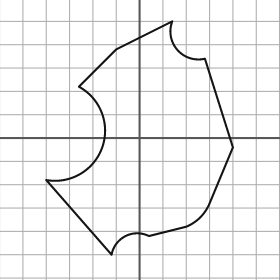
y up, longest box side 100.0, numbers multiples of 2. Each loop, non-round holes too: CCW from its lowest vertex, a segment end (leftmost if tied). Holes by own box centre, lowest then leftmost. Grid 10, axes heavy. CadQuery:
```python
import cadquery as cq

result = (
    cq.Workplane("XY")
    .moveTo(-12.0, -50.0)
    .threePointArc((-6.0, -42.0), (4.0, -42.0))
    .lineTo(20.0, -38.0)
    .threePointArc((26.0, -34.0), (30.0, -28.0))
    .lineTo(40.0, -4.0)
    .lineTo(28.0, 34.0)
    .threePointArc((16.0, 38.0), (14.0, 50.0))
    .lineTo(-10.0, 38.0)
    .lineTo(-26.0, 22.0)
    .threePointArc((-16.0, -4.0), (-40.0, -18.0))
    .close()
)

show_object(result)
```